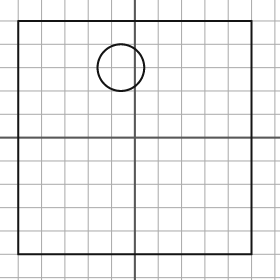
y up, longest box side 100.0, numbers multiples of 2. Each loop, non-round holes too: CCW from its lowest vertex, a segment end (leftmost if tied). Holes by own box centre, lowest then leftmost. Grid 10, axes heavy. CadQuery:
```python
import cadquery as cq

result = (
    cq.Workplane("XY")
    .moveTo(-50.0, -50.0)
    .lineTo(50.0, -50.0)
    .lineTo(50.0, 50.0)
    .lineTo(-50.0, 50.0)
    .close()
    .moveTo(-6.0, 30.0)
    .circle(10.0)
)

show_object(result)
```